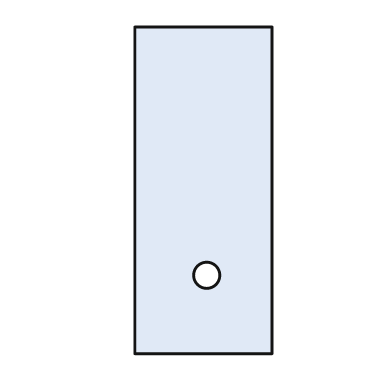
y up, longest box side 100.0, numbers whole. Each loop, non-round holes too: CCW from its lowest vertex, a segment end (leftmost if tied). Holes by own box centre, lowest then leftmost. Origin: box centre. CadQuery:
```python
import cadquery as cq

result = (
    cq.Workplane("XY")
    .moveTo(-21.0, -50.0)
    .lineTo(21.0, -50.0)
    .lineTo(21.0, 50.0)
    .lineTo(-21.0, 50.0)
    .close()
    .moveTo(1.0, -26.0)
    .circle(4.0)
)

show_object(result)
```